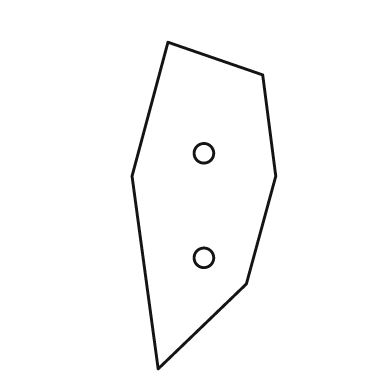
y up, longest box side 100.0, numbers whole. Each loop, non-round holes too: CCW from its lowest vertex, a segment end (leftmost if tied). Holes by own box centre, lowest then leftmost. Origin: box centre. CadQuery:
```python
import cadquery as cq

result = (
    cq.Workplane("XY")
    .moveTo(-14.0, -50.0)
    .lineTo(13.0, -24.0)
    .lineTo(22.0, 9.0)
    .lineTo(18.0, 40.0)
    .lineTo(-11.0, 50.0)
    .lineTo(-22.0, 9.0)
    .close()
    .moveTo(0.0, -16.0)
    .circle(3.0)
    .moveTo(0.0, 16.0)
    .circle(3.0)
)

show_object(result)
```